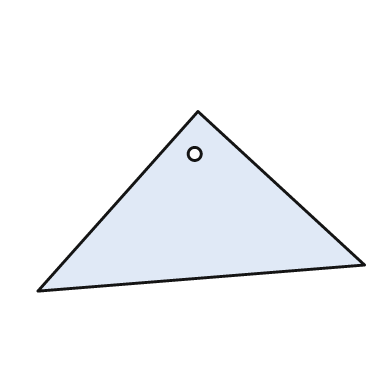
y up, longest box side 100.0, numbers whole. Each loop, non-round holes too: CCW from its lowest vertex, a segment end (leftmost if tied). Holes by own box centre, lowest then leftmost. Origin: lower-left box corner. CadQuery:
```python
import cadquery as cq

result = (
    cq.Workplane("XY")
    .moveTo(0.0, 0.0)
    .lineTo(100.0, 8.0)
    .lineTo(49.0, 55.0)
    .close()
    .moveTo(48.0, 42.0)
    .circle(2.0)
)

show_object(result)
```